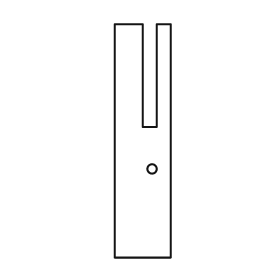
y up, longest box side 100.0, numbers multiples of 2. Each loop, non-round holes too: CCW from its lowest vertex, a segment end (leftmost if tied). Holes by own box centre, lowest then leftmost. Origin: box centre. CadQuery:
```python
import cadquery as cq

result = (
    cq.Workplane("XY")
    .moveTo(-12.0, -50.0)
    .lineTo(12.0, -50.0)
    .lineTo(12.0, 50.0)
    .lineTo(6.0, 50.0)
    .lineTo(6.0, 6.0)
    .lineTo(0.0, 6.0)
    .lineTo(0.0, 50.0)
    .lineTo(-12.0, 50.0)
    .close()
    .moveTo(4.0, -12.0)
    .circle(2.0)
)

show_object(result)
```